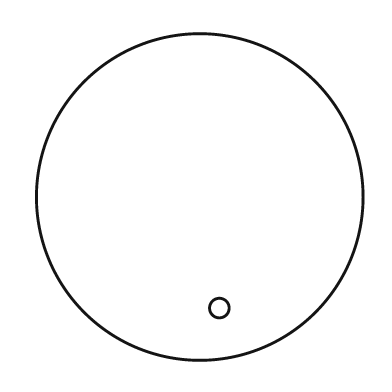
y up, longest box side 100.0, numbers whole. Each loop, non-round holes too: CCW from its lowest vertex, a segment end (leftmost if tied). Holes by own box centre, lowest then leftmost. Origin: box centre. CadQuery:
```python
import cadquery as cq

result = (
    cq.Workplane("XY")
    .moveTo(0.0, 0.0)
    .circle(50.0)
    .moveTo(6.0, -34.0)
    .circle(3.0)
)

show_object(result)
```